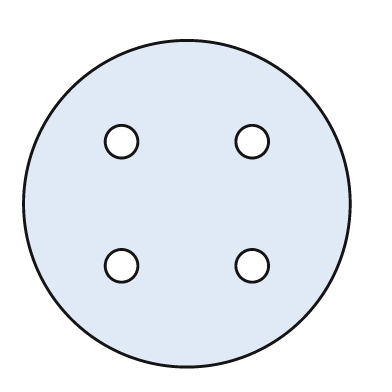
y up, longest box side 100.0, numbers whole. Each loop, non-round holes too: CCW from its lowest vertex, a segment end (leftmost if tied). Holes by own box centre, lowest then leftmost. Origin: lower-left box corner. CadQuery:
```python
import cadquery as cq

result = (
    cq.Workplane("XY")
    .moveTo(50.0, 50.0)
    .circle(50.0)
    .moveTo(30.0, 31.0)
    .circle(5.0)
    .moveTo(70.0, 31.0)
    .circle(5.0)
    .moveTo(30.0, 69.0)
    .circle(5.0)
    .moveTo(70.0, 69.0)
    .circle(5.0)
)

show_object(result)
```